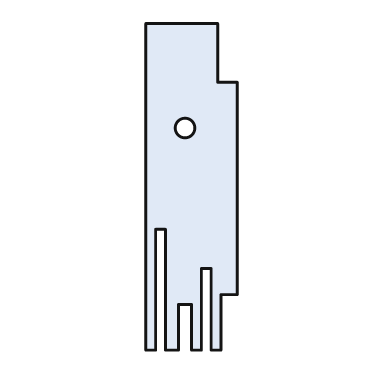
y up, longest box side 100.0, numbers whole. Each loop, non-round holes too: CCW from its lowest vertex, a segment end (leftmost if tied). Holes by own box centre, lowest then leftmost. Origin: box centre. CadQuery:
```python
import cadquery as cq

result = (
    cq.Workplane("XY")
    .moveTo(-14.0, -50.0)
    .lineTo(-11.0, -50.0)
    .lineTo(-11.0, -13.0)
    .lineTo(-8.0, -13.0)
    .lineTo(-8.0, -50.0)
    .lineTo(-4.0, -50.0)
    .lineTo(-4.0, -36.0)
    .lineTo(0.0, -36.0)
    .lineTo(0.0, -50.0)
    .lineTo(3.0, -50.0)
    .lineTo(3.0, -25.0)
    .lineTo(6.0, -25.0)
    .lineTo(6.0, -50.0)
    .lineTo(9.0, -50.0)
    .lineTo(9.0, -33.0)
    .lineTo(14.0, -33.0)
    .lineTo(14.0, 32.0)
    .lineTo(8.0, 32.0)
    .lineTo(8.0, 50.0)
    .lineTo(-14.0, 50.0)
    .close()
    .moveTo(-2.0, 18.0)
    .circle(3.0)
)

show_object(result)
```